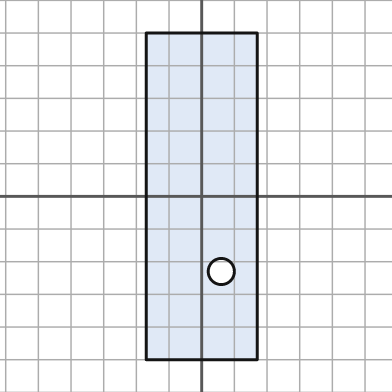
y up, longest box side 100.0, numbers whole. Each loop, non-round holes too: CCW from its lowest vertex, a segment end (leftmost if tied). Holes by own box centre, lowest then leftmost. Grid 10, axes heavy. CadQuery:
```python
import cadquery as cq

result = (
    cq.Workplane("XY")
    .moveTo(-17.0, -50.0)
    .lineTo(17.0, -50.0)
    .lineTo(17.0, 50.0)
    .lineTo(-17.0, 50.0)
    .close()
    .moveTo(6.0, -23.0)
    .circle(4.0)
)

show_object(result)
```